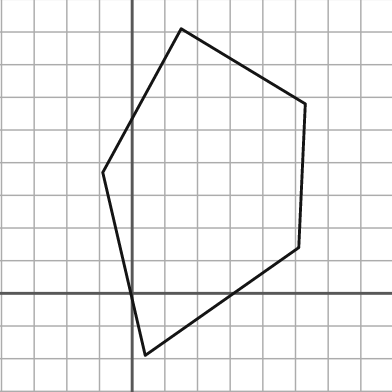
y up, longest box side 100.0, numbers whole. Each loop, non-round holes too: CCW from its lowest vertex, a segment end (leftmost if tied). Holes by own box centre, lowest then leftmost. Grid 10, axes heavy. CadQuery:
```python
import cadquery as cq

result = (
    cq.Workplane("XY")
    .moveTo(4.0, -19.0)
    .lineTo(51.0, 14.0)
    .lineTo(53.0, 58.0)
    .lineTo(15.0, 81.0)
    .lineTo(-9.0, 37.0)
    .close()
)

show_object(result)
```